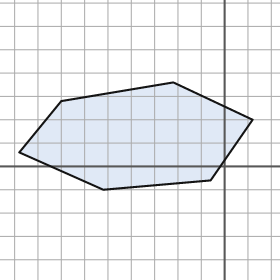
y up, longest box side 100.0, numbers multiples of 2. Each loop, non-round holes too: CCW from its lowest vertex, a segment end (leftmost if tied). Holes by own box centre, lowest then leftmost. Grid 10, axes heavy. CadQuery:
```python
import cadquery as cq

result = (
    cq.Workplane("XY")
    .moveTo(-52.0, -10.0)
    .lineTo(-6.0, -6.0)
    .lineTo(12.0, 20.0)
    .lineTo(-22.0, 36.0)
    .lineTo(-70.0, 28.0)
    .lineTo(-88.0, 6.0)
    .close()
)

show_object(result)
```